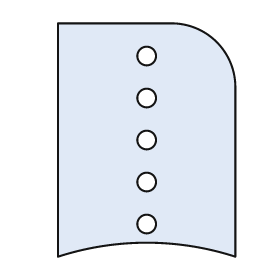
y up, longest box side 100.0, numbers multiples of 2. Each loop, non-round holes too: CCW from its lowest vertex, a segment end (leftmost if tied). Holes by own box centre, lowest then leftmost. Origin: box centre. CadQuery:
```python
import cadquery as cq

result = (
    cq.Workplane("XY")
    .moveTo(-38.0, -50.0)
    .threePointArc((0.0, -44.0), (38.0, -50.0))
    .lineTo(38.0, 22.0)
    .threePointArc((30.0, 42.0), (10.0, 50.0))
    .lineTo(-38.0, 50.0)
    .close()
    .moveTo(0.0, -36.0)
    .circle(4.0)
    .moveTo(0.0, -18.0)
    .circle(4.0)
    .moveTo(0.0, 0.0)
    .circle(4.0)
    .moveTo(0.0, 18.0)
    .circle(4.0)
    .moveTo(0.0, 36.0)
    .circle(4.0)
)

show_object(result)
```